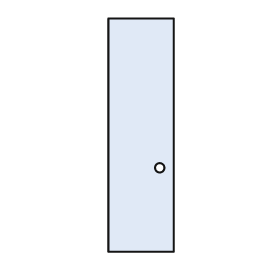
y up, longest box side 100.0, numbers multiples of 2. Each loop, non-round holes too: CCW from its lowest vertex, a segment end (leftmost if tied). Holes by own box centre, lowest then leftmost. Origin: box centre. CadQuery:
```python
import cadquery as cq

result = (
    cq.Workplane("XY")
    .moveTo(-14.0, -50.0)
    .lineTo(14.0, -50.0)
    .lineTo(14.0, 50.0)
    .lineTo(-14.0, 50.0)
    .close()
    .moveTo(8.0, -14.0)
    .circle(2.0)
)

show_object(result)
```